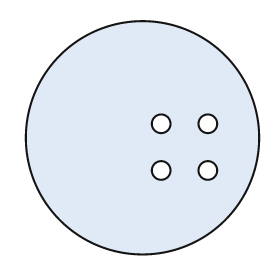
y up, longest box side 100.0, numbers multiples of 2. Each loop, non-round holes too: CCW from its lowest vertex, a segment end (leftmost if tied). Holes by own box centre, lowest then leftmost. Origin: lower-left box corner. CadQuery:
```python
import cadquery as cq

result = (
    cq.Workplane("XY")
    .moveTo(50.0, 50.0)
    .circle(50.0)
    .moveTo(58.0, 36.0)
    .circle(4.0)
    .moveTo(78.0, 36.0)
    .circle(4.0)
    .moveTo(58.0, 56.0)
    .circle(4.0)
    .moveTo(78.0, 56.0)
    .circle(4.0)
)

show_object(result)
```